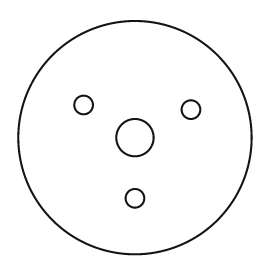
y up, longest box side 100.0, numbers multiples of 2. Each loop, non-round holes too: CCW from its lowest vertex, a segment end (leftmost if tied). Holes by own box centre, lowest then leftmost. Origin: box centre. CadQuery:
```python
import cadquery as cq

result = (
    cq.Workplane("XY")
    .moveTo(0.0, 0.0)
    .circle(50.0)
    .moveTo(0.0, -26.0)
    .circle(4.0)
    .moveTo(0.0, 0.0)
    .circle(8.0)
    .moveTo(24.0, 12.0)
    .circle(4.0)
    .moveTo(-22.0, 14.0)
    .circle(4.0)
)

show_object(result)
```